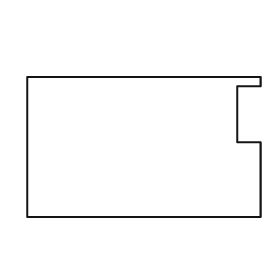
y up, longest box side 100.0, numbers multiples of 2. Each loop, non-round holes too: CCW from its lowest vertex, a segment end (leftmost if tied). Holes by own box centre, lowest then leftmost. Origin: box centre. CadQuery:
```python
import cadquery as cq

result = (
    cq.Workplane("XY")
    .moveTo(-50.0, -30.0)
    .lineTo(50.0, -30.0)
    .lineTo(50.0, 2.0)
    .lineTo(40.0, 2.0)
    .lineTo(40.0, 26.0)
    .lineTo(50.0, 26.0)
    .lineTo(50.0, 30.0)
    .lineTo(-50.0, 30.0)
    .close()
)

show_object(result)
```